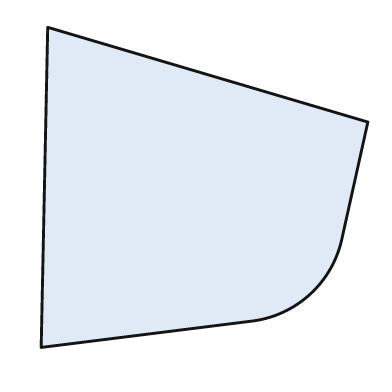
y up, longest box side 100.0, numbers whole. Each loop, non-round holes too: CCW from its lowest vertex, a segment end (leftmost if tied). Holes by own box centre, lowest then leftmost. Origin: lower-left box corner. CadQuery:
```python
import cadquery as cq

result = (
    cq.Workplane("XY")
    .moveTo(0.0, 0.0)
    .lineTo(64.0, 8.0)
    .threePointArc((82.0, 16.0), (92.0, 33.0))
    .lineTo(100.0, 69.0)
    .lineTo(2.0, 98.0)
    .close()
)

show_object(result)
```